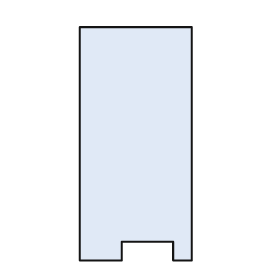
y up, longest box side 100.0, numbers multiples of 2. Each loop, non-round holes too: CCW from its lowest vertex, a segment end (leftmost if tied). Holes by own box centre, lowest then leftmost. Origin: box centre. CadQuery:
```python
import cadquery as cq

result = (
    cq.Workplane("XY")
    .moveTo(-24.0, -50.0)
    .lineTo(-6.0, -50.0)
    .lineTo(-6.0, -42.0)
    .lineTo(16.0, -42.0)
    .lineTo(16.0, -50.0)
    .lineTo(24.0, -50.0)
    .lineTo(24.0, 50.0)
    .lineTo(-24.0, 50.0)
    .close()
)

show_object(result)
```